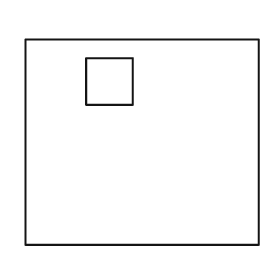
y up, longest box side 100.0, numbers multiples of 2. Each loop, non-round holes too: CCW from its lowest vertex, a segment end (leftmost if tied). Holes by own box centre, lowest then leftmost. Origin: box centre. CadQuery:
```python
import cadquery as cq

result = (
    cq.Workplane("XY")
    .moveTo(-50.0, -44.0)
    .lineTo(50.0, -44.0)
    .lineTo(50.0, 44.0)
    .lineTo(-50.0, 44.0)
    .close()
    .moveTo(-24.0, 16.0)
    .lineTo(-4.0, 16.0)
    .lineTo(-4.0, 36.0)
    .lineTo(-24.0, 36.0)
    .close()
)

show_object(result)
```